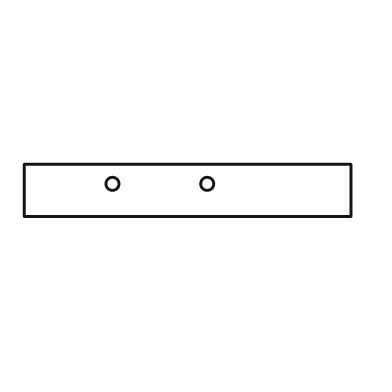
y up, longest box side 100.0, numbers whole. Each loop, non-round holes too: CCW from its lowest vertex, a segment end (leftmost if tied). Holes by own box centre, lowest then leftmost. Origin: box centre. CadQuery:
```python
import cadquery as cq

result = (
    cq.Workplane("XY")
    .moveTo(-50.0, -8.0)
    .lineTo(50.0, -8.0)
    .lineTo(50.0, 8.0)
    .lineTo(-50.0, 8.0)
    .close()
    .moveTo(-23.0, 2.0)
    .circle(2.0)
    .moveTo(6.0, 2.0)
    .circle(2.0)
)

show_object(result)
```